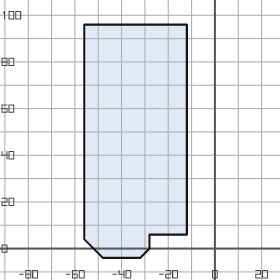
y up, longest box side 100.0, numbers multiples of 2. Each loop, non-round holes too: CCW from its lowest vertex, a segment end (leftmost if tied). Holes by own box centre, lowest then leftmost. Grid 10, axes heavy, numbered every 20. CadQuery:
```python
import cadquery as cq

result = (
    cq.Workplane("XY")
    .moveTo(-48.0, -4.0)
    .lineTo(-32.0, -4.0)
    .lineTo(-28.0, 0.0)
    .lineTo(-28.0, 6.0)
    .lineTo(-12.0, 6.0)
    .lineTo(-12.0, 96.0)
    .lineTo(-56.0, 96.0)
    .lineTo(-56.0, 4.0)
    .close()
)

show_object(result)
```